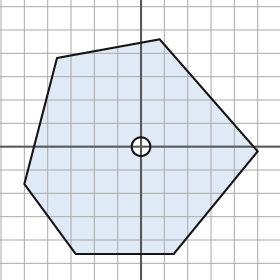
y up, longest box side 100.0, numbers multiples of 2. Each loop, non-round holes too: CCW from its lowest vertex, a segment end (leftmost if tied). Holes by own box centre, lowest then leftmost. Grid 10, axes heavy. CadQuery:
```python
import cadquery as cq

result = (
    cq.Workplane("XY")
    .moveTo(-28.0, -46.0)
    .lineTo(14.0, -46.0)
    .lineTo(50.0, -2.0)
    .lineTo(8.0, 46.0)
    .lineTo(-36.0, 38.0)
    .lineTo(-50.0, -16.0)
    .close()
    .moveTo(0.0, 0.0)
    .circle(4.0)
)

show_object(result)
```